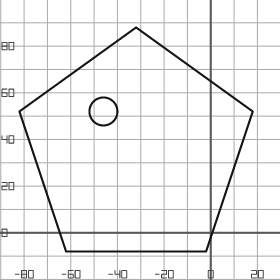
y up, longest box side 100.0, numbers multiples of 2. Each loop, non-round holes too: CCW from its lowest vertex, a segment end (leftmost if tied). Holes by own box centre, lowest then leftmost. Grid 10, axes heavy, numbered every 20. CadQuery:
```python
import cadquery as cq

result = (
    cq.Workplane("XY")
    .moveTo(-62.0, -8.0)
    .lineTo(-2.0, -8.0)
    .lineTo(18.0, 52.0)
    .lineTo(-32.0, 88.0)
    .lineTo(-82.0, 52.0)
    .close()
    .moveTo(-46.0, 52.0)
    .circle(6.0)
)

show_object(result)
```